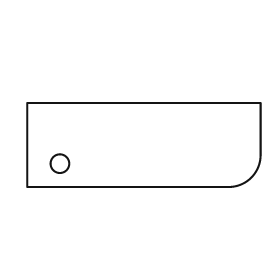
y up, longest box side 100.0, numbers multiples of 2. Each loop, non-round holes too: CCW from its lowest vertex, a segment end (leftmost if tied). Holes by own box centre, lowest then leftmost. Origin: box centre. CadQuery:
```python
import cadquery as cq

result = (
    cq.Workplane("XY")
    .moveTo(-50.0, -18.0)
    .lineTo(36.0, -18.0)
    .threePointArc((46.0, -14.0), (50.0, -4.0))
    .lineTo(50.0, 18.0)
    .lineTo(-50.0, 18.0)
    .close()
    .moveTo(-36.0, -8.0)
    .circle(4.0)
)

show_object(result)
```